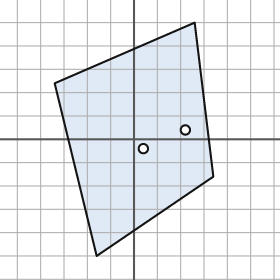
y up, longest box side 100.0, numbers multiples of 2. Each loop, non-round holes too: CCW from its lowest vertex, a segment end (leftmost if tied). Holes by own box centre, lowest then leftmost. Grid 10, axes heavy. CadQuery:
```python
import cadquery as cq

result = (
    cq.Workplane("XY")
    .moveTo(-16.0, -50.0)
    .lineTo(34.0, -16.0)
    .lineTo(26.0, 50.0)
    .lineTo(-34.0, 24.0)
    .close()
    .moveTo(4.0, -4.0)
    .circle(2.0)
    .moveTo(22.0, 4.0)
    .circle(2.0)
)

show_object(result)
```